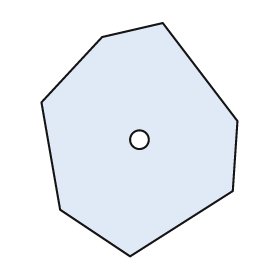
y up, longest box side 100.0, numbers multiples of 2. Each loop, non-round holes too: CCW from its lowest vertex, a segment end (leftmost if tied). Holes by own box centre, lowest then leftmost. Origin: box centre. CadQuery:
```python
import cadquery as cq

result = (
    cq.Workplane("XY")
    .moveTo(-4.0, -50.0)
    .lineTo(40.0, -22.0)
    .lineTo(42.0, 8.0)
    .lineTo(10.0, 50.0)
    .lineTo(-16.0, 44.0)
    .lineTo(-42.0, 16.0)
    .lineTo(-34.0, -30.0)
    .close()
    .moveTo(0.0, 0.0)
    .circle(4.0)
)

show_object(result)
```